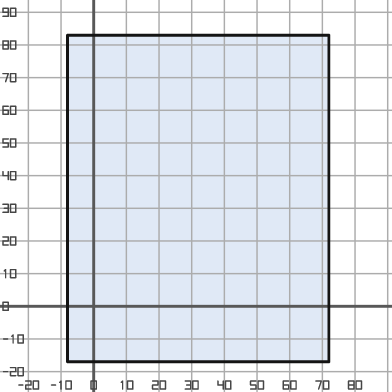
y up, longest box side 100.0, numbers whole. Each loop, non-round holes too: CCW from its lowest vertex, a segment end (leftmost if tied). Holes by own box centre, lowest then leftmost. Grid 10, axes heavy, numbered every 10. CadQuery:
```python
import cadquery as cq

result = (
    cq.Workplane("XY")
    .moveTo(-8.0, -17.0)
    .lineTo(72.0, -17.0)
    .lineTo(72.0, 83.0)
    .lineTo(-8.0, 83.0)
    .close()
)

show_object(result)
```